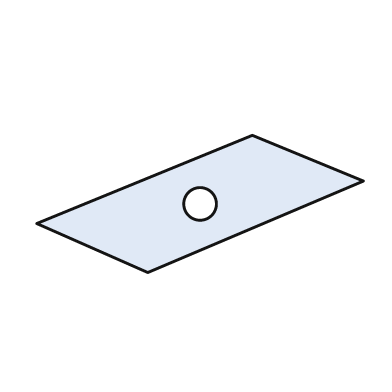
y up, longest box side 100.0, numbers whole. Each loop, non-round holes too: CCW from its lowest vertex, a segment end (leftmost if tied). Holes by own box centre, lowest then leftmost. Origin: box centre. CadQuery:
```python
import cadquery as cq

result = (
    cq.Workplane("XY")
    .moveTo(-16.0, -21.0)
    .lineTo(50.0, 7.0)
    .lineTo(16.0, 21.0)
    .lineTo(-50.0, -6.0)
    .close()
    .moveTo(0.0, 0.0)
    .circle(5.0)
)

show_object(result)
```